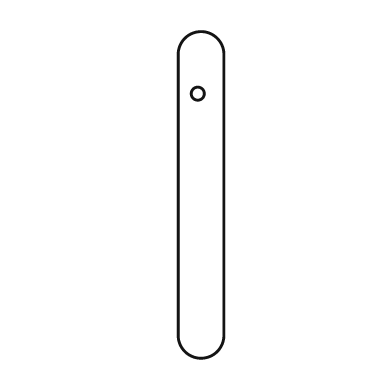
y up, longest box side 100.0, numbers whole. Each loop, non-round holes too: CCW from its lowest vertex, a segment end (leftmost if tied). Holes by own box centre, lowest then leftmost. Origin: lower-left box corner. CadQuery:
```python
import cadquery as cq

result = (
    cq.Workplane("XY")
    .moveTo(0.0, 7.0)
    .threePointArc((7.0, 0.0), (14.0, 7.0))
    .lineTo(14.0, 93.0)
    .threePointArc((7.0, 100.0), (0.0, 93.0))
    .close()
    .moveTo(6.0, 81.0)
    .circle(2.0)
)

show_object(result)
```